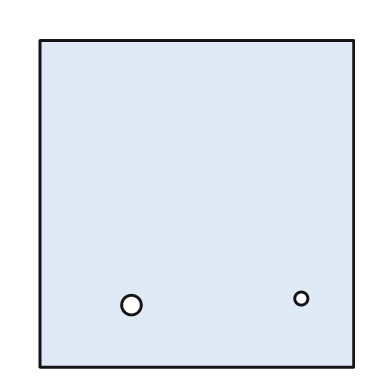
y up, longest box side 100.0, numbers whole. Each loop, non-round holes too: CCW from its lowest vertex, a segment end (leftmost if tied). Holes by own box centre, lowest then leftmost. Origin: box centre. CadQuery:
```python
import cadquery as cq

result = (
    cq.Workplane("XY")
    .moveTo(-48.0, -50.0)
    .lineTo(48.0, -50.0)
    .lineTo(48.0, 50.0)
    .lineTo(-48.0, 50.0)
    .close()
    .moveTo(-20.0, -31.0)
    .circle(3.0)
    .moveTo(32.0, -29.0)
    .circle(2.0)
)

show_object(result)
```